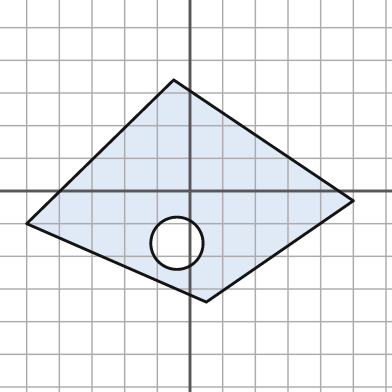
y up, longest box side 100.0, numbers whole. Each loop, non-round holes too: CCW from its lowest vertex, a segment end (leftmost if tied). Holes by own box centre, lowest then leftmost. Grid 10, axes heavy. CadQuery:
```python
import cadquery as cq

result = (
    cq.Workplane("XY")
    .moveTo(5.0, -34.0)
    .lineTo(50.0, -3.0)
    .lineTo(-5.0, 34.0)
    .lineTo(-50.0, -10.0)
    .close()
    .moveTo(-4.0, -16.0)
    .circle(8.0)
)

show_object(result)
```